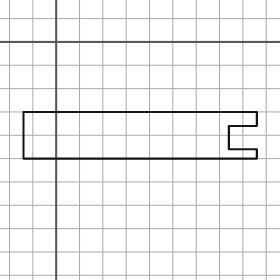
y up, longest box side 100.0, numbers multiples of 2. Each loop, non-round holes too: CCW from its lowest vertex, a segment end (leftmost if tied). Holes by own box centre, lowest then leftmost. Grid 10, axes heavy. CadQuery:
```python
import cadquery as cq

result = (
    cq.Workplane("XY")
    .moveTo(-14.0, -50.0)
    .lineTo(86.0, -50.0)
    .lineTo(86.0, -46.0)
    .lineTo(74.0, -46.0)
    .lineTo(74.0, -36.0)
    .lineTo(86.0, -36.0)
    .lineTo(86.0, -30.0)
    .lineTo(-14.0, -30.0)
    .close()
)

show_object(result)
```